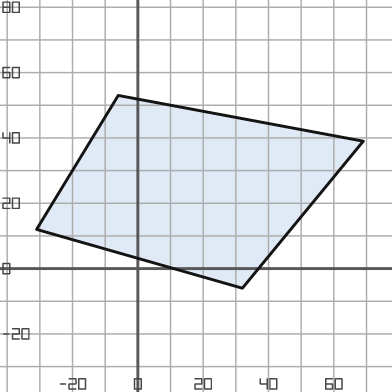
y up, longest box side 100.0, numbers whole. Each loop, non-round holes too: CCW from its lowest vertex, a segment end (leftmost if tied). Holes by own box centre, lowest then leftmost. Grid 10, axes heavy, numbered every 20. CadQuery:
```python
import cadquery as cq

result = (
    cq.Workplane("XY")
    .moveTo(32.0, -6.0)
    .lineTo(69.0, 39.0)
    .lineTo(-6.0, 53.0)
    .lineTo(-31.0, 12.0)
    .close()
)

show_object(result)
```